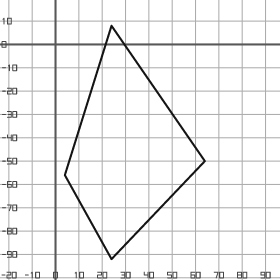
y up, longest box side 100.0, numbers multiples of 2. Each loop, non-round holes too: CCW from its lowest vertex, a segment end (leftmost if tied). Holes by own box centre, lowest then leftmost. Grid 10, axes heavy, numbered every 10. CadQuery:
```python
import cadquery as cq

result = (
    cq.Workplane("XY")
    .moveTo(24.0, -92.0)
    .lineTo(64.0, -50.0)
    .lineTo(24.0, 8.0)
    .lineTo(4.0, -56.0)
    .close()
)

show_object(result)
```